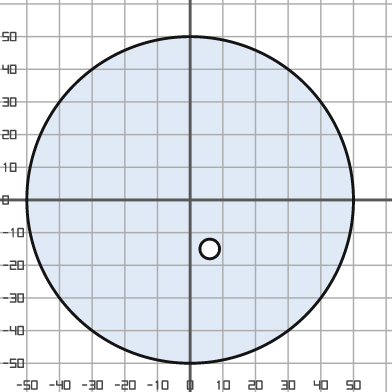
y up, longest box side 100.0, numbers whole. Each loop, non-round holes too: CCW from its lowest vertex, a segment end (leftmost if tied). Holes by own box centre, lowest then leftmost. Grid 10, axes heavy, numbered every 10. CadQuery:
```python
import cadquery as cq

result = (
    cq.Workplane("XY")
    .moveTo(0.0, 0.0)
    .circle(50.0)
    .moveTo(6.0, -15.0)
    .circle(3.0)
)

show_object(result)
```